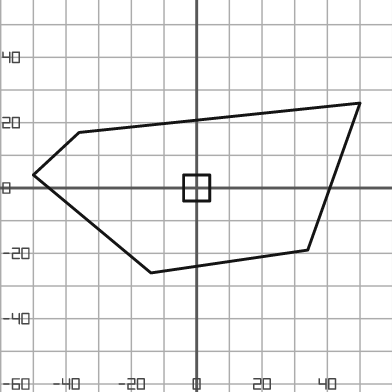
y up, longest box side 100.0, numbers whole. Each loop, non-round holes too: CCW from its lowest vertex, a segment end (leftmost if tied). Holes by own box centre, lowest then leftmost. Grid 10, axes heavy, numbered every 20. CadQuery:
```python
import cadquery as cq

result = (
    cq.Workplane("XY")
    .moveTo(-14.0, -26.0)
    .lineTo(34.0, -19.0)
    .lineTo(50.0, 26.0)
    .lineTo(-36.0, 17.0)
    .lineTo(-50.0, 4.0)
    .close()
    .moveTo(-4.0, -4.0)
    .lineTo(4.0, -4.0)
    .lineTo(4.0, 4.0)
    .lineTo(-4.0, 4.0)
    .close()
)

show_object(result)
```